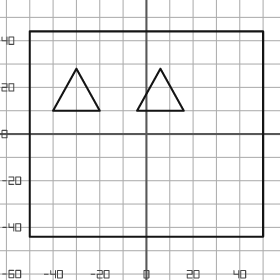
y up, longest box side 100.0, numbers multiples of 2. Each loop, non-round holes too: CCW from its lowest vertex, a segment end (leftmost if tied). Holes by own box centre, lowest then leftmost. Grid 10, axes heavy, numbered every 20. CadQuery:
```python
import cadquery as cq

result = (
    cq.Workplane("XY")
    .moveTo(-50.0, -44.0)
    .lineTo(50.0, -44.0)
    .lineTo(50.0, 44.0)
    .lineTo(-50.0, 44.0)
    .close()
    .moveTo(-40.0, 10.0)
    .lineTo(-20.0, 10.0)
    .lineTo(-30.0, 28.0)
    .close()
    .moveTo(-4.0, 10.0)
    .lineTo(16.0, 10.0)
    .lineTo(6.0, 28.0)
    .close()
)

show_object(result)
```